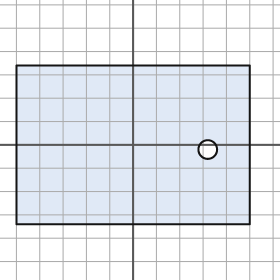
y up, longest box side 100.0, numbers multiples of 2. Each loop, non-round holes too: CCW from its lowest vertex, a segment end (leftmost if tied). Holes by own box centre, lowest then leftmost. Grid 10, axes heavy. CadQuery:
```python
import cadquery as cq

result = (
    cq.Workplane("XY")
    .moveTo(-50.0, -34.0)
    .lineTo(50.0, -34.0)
    .lineTo(50.0, 34.0)
    .lineTo(-50.0, 34.0)
    .close()
    .moveTo(32.0, -2.0)
    .circle(4.0)
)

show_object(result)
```